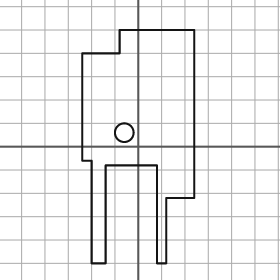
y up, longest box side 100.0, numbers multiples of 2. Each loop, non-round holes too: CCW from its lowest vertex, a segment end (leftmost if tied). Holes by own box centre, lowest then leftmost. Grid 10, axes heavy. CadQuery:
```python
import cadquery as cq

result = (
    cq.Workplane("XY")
    .moveTo(-20.0, -50.0)
    .lineTo(-14.0, -50.0)
    .lineTo(-14.0, -8.0)
    .lineTo(8.0, -8.0)
    .lineTo(8.0, -50.0)
    .lineTo(12.0, -50.0)
    .lineTo(12.0, -22.0)
    .lineTo(24.0, -22.0)
    .lineTo(24.0, 50.0)
    .lineTo(-8.0, 50.0)
    .lineTo(-8.0, 40.0)
    .lineTo(-24.0, 40.0)
    .lineTo(-24.0, -6.0)
    .lineTo(-20.0, -6.0)
    .close()
    .moveTo(-6.0, 6.0)
    .circle(4.0)
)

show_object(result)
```